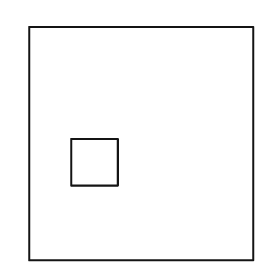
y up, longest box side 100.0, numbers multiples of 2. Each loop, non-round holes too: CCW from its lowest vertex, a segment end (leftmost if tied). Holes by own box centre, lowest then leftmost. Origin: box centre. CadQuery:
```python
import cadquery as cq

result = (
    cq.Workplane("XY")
    .moveTo(-48.0, -50.0)
    .lineTo(48.0, -50.0)
    .lineTo(48.0, 50.0)
    .lineTo(-48.0, 50.0)
    .close()
    .moveTo(-30.0, -18.0)
    .lineTo(-10.0, -18.0)
    .lineTo(-10.0, 2.0)
    .lineTo(-30.0, 2.0)
    .close()
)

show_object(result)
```